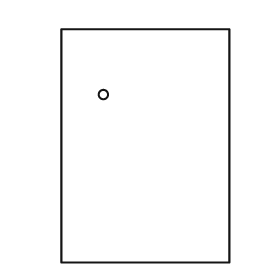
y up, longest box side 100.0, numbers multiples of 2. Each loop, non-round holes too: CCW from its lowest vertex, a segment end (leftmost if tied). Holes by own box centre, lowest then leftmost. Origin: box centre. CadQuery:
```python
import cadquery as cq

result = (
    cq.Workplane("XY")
    .moveTo(-36.0, -50.0)
    .lineTo(36.0, -50.0)
    .lineTo(36.0, 50.0)
    .lineTo(-36.0, 50.0)
    .close()
    .moveTo(-18.0, 22.0)
    .circle(2.0)
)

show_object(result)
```